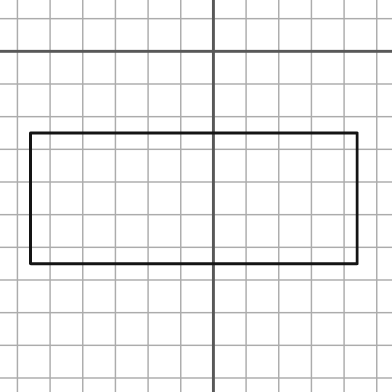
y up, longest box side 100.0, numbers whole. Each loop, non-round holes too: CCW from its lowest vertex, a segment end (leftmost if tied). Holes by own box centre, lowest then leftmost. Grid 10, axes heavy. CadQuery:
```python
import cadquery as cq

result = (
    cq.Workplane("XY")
    .moveTo(-56.0, -65.0)
    .lineTo(44.0, -65.0)
    .lineTo(44.0, -25.0)
    .lineTo(-56.0, -25.0)
    .close()
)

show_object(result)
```